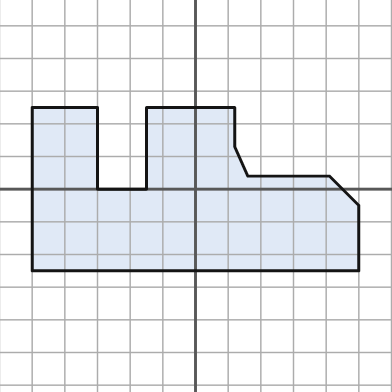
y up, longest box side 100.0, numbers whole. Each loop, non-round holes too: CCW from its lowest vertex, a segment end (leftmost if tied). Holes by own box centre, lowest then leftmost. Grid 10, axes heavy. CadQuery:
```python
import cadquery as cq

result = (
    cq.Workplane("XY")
    .moveTo(-50.0, -25.0)
    .lineTo(50.0, -25.0)
    .lineTo(50.0, -5.0)
    .lineTo(41.0, 4.0)
    .lineTo(16.0, 4.0)
    .lineTo(12.0, 13.0)
    .lineTo(12.0, 25.0)
    .lineTo(-15.0, 25.0)
    .lineTo(-15.0, 0.0)
    .lineTo(-30.0, 0.0)
    .lineTo(-30.0, 25.0)
    .lineTo(-50.0, 25.0)
    .close()
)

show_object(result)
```